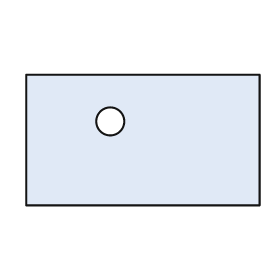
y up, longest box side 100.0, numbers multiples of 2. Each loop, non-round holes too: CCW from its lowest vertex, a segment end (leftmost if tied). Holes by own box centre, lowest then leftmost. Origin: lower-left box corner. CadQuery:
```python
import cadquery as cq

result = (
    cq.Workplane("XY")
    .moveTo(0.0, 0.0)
    .lineTo(100.0, 0.0)
    .lineTo(100.0, 56.0)
    .lineTo(0.0, 56.0)
    .close()
    .moveTo(36.0, 36.0)
    .circle(6.0)
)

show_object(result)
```